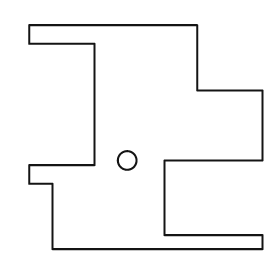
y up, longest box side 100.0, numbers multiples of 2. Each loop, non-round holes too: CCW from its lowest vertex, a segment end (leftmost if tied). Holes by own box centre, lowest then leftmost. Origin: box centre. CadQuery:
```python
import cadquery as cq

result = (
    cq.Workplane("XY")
    .moveTo(-40.0, -48.0)
    .lineTo(50.0, -48.0)
    .lineTo(50.0, -42.0)
    .lineTo(8.0, -42.0)
    .lineTo(8.0, -10.0)
    .lineTo(50.0, -10.0)
    .lineTo(50.0, 20.0)
    .lineTo(22.0, 20.0)
    .lineTo(22.0, 48.0)
    .lineTo(-50.0, 48.0)
    .lineTo(-50.0, 40.0)
    .lineTo(-22.0, 40.0)
    .lineTo(-22.0, -12.0)
    .lineTo(-50.0, -12.0)
    .lineTo(-50.0, -20.0)
    .lineTo(-40.0, -20.0)
    .close()
    .moveTo(-8.0, -10.0)
    .circle(4.0)
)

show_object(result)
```